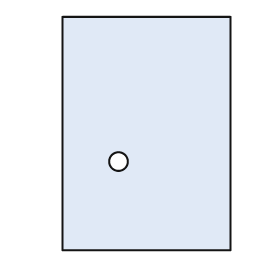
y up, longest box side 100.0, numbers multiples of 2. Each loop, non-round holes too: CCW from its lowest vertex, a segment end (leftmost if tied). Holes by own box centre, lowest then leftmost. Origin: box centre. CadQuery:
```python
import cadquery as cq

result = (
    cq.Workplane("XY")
    .moveTo(-36.0, -50.0)
    .lineTo(36.0, -50.0)
    .lineTo(36.0, 50.0)
    .lineTo(-36.0, 50.0)
    .close()
    .moveTo(-12.0, -12.0)
    .circle(4.0)
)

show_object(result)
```